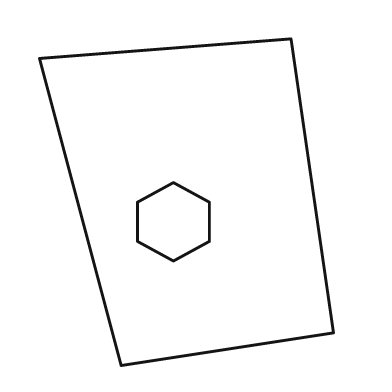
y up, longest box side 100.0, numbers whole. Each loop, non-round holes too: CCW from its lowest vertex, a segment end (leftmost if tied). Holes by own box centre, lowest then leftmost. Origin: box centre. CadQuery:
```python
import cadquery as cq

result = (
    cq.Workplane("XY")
    .moveTo(-20.0, -50.0)
    .lineTo(45.0, -40.0)
    .lineTo(32.0, 50.0)
    .lineTo(-45.0, 44.0)
    .close()
    .moveTo(-4.0, -18.0)
    .lineTo(7.0, -12.0)
    .lineTo(7.0, 0.0)
    .lineTo(-4.0, 6.0)
    .lineTo(-15.0, 0.0)
    .lineTo(-15.0, -12.0)
    .close()
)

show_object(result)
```